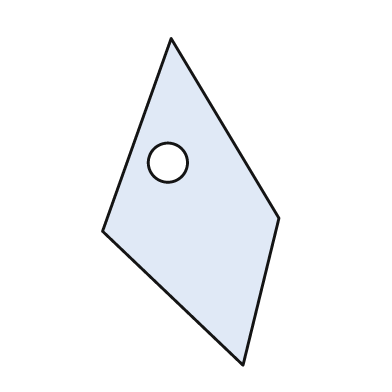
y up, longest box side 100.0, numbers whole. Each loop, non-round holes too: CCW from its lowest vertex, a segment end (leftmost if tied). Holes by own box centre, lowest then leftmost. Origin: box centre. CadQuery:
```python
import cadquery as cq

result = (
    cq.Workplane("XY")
    .moveTo(16.0, -50.0)
    .lineTo(27.0, -5.0)
    .lineTo(-6.0, 50.0)
    .lineTo(-27.0, -9.0)
    .close()
    .moveTo(-7.0, 12.0)
    .circle(6.0)
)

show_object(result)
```